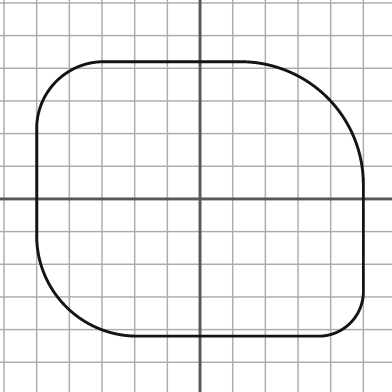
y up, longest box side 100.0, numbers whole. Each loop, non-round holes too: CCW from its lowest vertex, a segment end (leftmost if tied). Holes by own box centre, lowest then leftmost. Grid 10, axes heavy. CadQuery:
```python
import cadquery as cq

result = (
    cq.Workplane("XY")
    .moveTo(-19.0, -42.0)
    .lineTo(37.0, -42.0)
    .threePointArc((46.0, -38.0), (50.0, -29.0))
    .lineTo(50.0, 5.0)
    .threePointArc((39.0, 31.0), (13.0, 42.0))
    .lineTo(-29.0, 42.0)
    .threePointArc((-44.0, 36.0), (-50.0, 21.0))
    .lineTo(-50.0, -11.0)
    .threePointArc((-41.0, -33.0), (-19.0, -42.0))
    .close()
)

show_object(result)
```